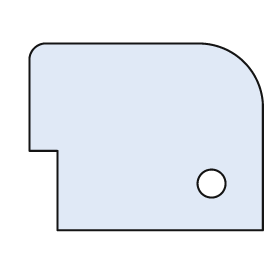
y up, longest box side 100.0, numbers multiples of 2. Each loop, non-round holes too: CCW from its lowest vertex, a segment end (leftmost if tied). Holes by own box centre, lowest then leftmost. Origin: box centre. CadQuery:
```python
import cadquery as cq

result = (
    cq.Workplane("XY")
    .moveTo(-38.0, -40.0)
    .lineTo(50.0, -40.0)
    .lineTo(50.0, 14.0)
    .threePointArc((42.0, 32.0), (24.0, 40.0))
    .lineTo(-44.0, 40.0)
    .threePointArc((-48.0, 38.0), (-50.0, 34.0))
    .lineTo(-50.0, -6.0)
    .lineTo(-38.0, -6.0)
    .close()
    .moveTo(28.0, -20.0)
    .circle(6.0)
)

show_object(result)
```